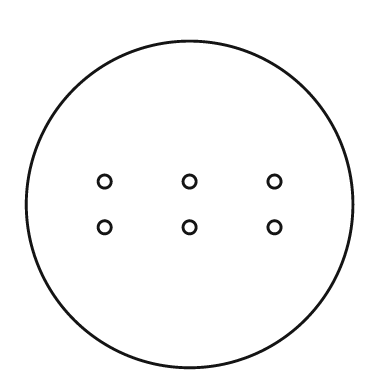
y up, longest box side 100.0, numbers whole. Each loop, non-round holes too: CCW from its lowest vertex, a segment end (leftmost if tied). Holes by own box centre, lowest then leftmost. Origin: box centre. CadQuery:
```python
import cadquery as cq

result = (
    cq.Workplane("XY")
    .moveTo(0.0, 0.0)
    .circle(50.0)
    .moveTo(-26.0, -7.0)
    .circle(2.0)
    .moveTo(0.0, -7.0)
    .circle(2.0)
    .moveTo(26.0, -7.0)
    .circle(2.0)
    .moveTo(-26.0, 7.0)
    .circle(2.0)
    .moveTo(0.0, 7.0)
    .circle(2.0)
    .moveTo(26.0, 7.0)
    .circle(2.0)
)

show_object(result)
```